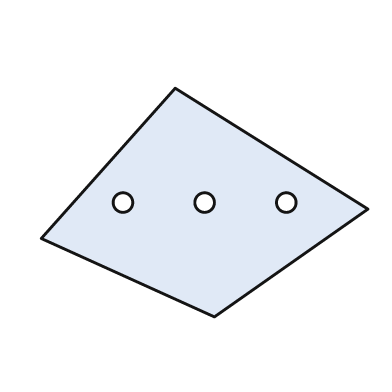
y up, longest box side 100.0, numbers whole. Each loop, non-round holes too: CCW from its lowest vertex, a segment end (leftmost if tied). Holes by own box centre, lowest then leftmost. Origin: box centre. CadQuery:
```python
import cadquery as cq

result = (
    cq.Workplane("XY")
    .moveTo(3.0, -35.0)
    .lineTo(50.0, -2.0)
    .lineTo(-9.0, 35.0)
    .lineTo(-50.0, -11.0)
    .close()
    .moveTo(-25.0, 0.0)
    .circle(3.0)
    .moveTo(0.0, 0.0)
    .circle(3.0)
    .moveTo(25.0, 0.0)
    .circle(3.0)
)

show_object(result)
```